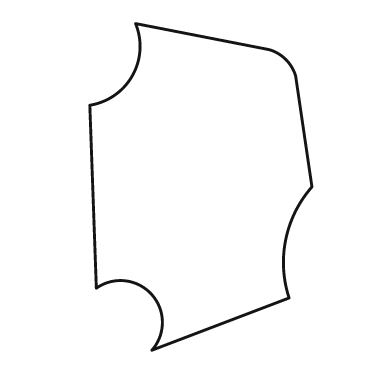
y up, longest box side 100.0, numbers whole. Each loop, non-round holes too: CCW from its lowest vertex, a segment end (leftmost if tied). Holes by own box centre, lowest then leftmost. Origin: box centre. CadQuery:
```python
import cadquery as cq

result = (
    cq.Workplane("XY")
    .moveTo(-15.0, -50.0)
    .lineTo(27.0, -34.0)
    .threePointArc((26.0, -16.0), (34.0, 0.0))
    .lineTo(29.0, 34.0)
    .threePointArc((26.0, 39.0), (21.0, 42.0))
    .lineTo(-20.0, 50.0)
    .threePointArc((-21.0, 34.0), (-34.0, 25.0))
    .lineTo(-32.0, -31.0)
    .threePointArc((-15.0, -33.0), (-15.0, -50.0))
    .close()
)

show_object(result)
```